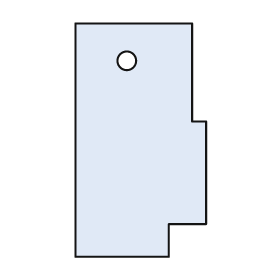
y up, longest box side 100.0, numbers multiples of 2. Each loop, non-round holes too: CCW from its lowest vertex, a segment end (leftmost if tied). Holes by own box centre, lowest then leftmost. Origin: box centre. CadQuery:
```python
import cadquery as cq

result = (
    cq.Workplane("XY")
    .moveTo(-28.0, -50.0)
    .lineTo(12.0, -50.0)
    .lineTo(12.0, -36.0)
    .lineTo(28.0, -36.0)
    .lineTo(28.0, 8.0)
    .lineTo(22.0, 8.0)
    .lineTo(22.0, 50.0)
    .lineTo(-28.0, 50.0)
    .close()
    .moveTo(-6.0, 34.0)
    .circle(4.0)
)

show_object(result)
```